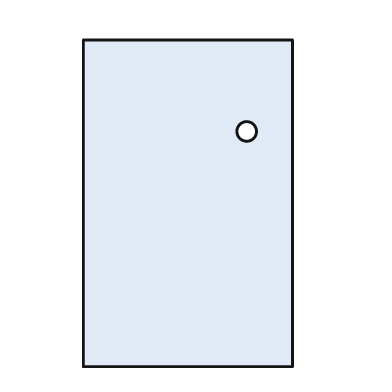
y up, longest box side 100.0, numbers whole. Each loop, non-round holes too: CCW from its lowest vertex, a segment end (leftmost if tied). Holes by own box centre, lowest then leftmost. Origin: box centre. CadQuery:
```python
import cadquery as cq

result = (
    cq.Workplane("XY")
    .moveTo(-32.0, -50.0)
    .lineTo(32.0, -50.0)
    .lineTo(32.0, 50.0)
    .lineTo(-32.0, 50.0)
    .close()
    .moveTo(18.0, 22.0)
    .circle(3.0)
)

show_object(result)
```